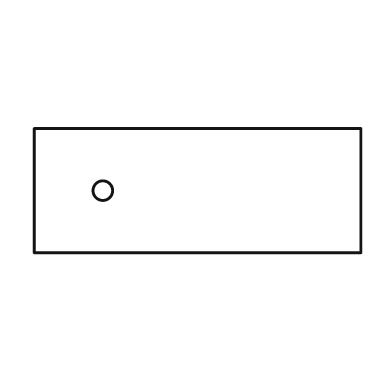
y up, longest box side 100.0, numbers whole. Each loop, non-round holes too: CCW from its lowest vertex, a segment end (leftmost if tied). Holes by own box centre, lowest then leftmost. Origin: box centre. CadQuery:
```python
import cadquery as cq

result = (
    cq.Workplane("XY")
    .moveTo(-50.0, -19.0)
    .lineTo(50.0, -19.0)
    .lineTo(50.0, 19.0)
    .lineTo(-50.0, 19.0)
    .close()
    .moveTo(-29.0, 0.0)
    .circle(3.0)
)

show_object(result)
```